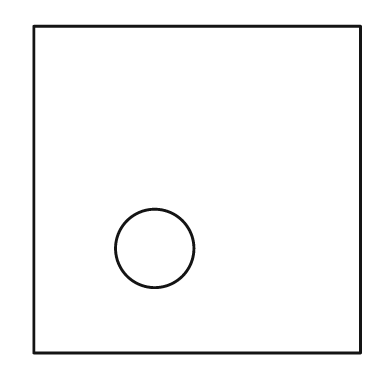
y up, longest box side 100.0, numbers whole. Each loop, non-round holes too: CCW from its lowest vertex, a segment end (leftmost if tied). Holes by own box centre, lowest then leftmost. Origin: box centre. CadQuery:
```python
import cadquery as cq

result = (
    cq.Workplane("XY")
    .moveTo(-50.0, -50.0)
    .lineTo(50.0, -50.0)
    .lineTo(50.0, 50.0)
    .lineTo(-50.0, 50.0)
    .close()
    .moveTo(-13.0, -18.0)
    .circle(12.0)
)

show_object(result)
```